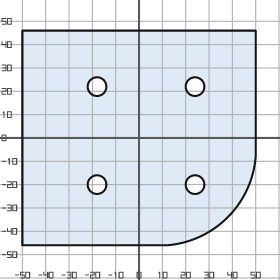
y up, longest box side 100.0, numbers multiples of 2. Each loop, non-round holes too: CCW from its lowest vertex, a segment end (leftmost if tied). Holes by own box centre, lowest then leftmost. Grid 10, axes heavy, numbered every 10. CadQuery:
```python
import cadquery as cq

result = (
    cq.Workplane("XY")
    .moveTo(-50.0, -46.0)
    .lineTo(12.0, -46.0)
    .threePointArc((38.0, -34.0), (50.0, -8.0))
    .lineTo(50.0, 46.0)
    .lineTo(-50.0, 46.0)
    .close()
    .moveTo(-18.0, -20.0)
    .circle(4.0)
    .moveTo(24.0, -20.0)
    .circle(4.0)
    .moveTo(-18.0, 22.0)
    .circle(4.0)
    .moveTo(24.0, 22.0)
    .circle(4.0)
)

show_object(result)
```